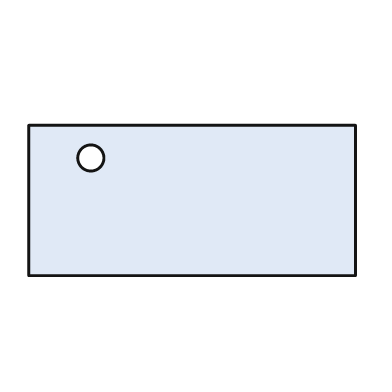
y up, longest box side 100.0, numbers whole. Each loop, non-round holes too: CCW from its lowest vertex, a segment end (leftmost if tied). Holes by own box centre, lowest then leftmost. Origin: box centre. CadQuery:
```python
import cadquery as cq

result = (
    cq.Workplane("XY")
    .moveTo(-50.0, -23.0)
    .lineTo(50.0, -23.0)
    .lineTo(50.0, 23.0)
    .lineTo(-50.0, 23.0)
    .close()
    .moveTo(-31.0, 13.0)
    .circle(4.0)
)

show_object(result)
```